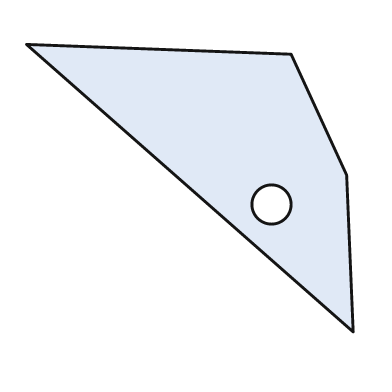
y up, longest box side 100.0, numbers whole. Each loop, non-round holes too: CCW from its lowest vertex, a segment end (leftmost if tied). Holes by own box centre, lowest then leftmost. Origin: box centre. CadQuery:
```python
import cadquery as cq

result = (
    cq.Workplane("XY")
    .moveTo(50.0, -44.0)
    .lineTo(48.0, 4.0)
    .lineTo(31.0, 41.0)
    .lineTo(-50.0, 44.0)
    .close()
    .moveTo(25.0, -5.0)
    .circle(6.0)
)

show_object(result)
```